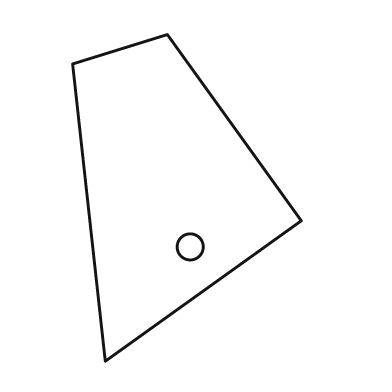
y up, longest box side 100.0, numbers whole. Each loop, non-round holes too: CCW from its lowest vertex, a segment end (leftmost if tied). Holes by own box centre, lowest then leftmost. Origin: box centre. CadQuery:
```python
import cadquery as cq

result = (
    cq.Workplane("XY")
    .moveTo(-25.0, -50.0)
    .lineTo(35.0, -7.0)
    .lineTo(-6.0, 50.0)
    .lineTo(-35.0, 41.0)
    .close()
    .moveTo(1.0, -15.0)
    .circle(4.0)
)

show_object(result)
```